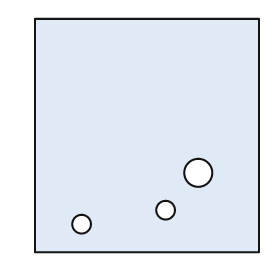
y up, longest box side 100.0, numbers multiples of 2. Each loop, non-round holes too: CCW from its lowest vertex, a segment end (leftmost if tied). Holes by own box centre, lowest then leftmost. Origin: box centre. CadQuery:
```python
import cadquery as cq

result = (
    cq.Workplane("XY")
    .moveTo(-48.0, -50.0)
    .lineTo(48.0, -50.0)
    .lineTo(48.0, 50.0)
    .lineTo(-48.0, 50.0)
    .close()
    .moveTo(-28.0, -38.0)
    .circle(4.0)
    .moveTo(8.0, -32.0)
    .circle(4.0)
    .moveTo(22.0, -16.0)
    .circle(6.0)
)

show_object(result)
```